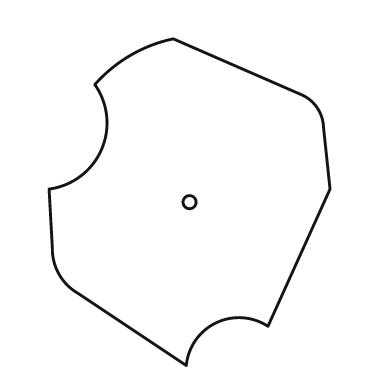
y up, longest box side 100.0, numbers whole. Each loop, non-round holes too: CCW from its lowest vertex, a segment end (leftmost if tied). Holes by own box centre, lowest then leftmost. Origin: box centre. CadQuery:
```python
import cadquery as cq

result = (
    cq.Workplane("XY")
    .moveTo(-1.0, -50.0)
    .threePointArc((8.0, -37.0), (24.0, -38.0))
    .lineTo(43.0, 4.0)
    .lineTo(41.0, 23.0)
    .threePointArc((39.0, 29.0), (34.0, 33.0))
    .lineTo(-5.0, 50.0)
    .threePointArc((-18.0, 45.0), (-29.0, 36.0))
    .threePointArc((-27.0, 16.0), (-43.0, 4.0))
    .lineTo(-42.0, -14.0)
    .threePointArc((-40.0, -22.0), (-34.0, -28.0))
    .close()
    .moveTo(0.0, 0.0)
    .circle(2.0)
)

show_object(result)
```